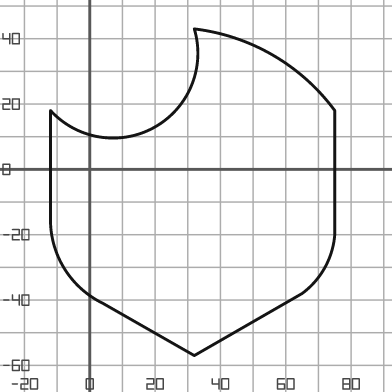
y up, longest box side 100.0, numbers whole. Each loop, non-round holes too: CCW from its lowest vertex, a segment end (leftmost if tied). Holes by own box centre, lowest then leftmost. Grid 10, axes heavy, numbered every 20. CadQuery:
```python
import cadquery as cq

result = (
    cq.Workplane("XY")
    .moveTo(32.0, -57.0)
    .lineTo(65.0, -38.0)
    .threePointArc((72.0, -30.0), (75.0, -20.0))
    .lineTo(75.0, 18.0)
    .threePointArc((56.0, 35.0), (32.0, 43.0))
    .threePointArc((20.0, 13.0), (-12.0, 18.0))
    .lineTo(-12.0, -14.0)
    .threePointArc((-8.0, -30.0), (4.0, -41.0))
    .close()
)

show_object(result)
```